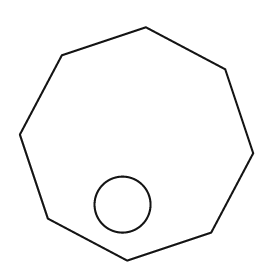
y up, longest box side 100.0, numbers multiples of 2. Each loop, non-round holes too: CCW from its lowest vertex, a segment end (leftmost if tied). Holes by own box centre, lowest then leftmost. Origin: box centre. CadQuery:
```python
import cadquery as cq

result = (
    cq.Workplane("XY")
    .moveTo(-4.0, -50.0)
    .lineTo(32.0, -38.0)
    .lineTo(50.0, -4.0)
    .lineTo(38.0, 32.0)
    .lineTo(4.0, 50.0)
    .lineTo(-32.0, 38.0)
    .lineTo(-50.0, 4.0)
    .lineTo(-38.0, -32.0)
    .close()
    .moveTo(-6.0, -26.0)
    .circle(12.0)
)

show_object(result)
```